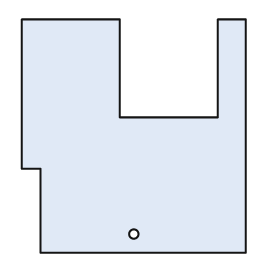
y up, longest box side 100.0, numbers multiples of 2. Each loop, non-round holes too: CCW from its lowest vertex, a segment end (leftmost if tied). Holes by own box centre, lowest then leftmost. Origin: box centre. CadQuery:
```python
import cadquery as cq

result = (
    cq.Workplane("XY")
    .moveTo(-40.0, -50.0)
    .lineTo(48.0, -50.0)
    .lineTo(48.0, 50.0)
    .lineTo(36.0, 50.0)
    .lineTo(36.0, 8.0)
    .lineTo(-6.0, 8.0)
    .lineTo(-6.0, 50.0)
    .lineTo(-48.0, 50.0)
    .lineTo(-48.0, -14.0)
    .lineTo(-40.0, -14.0)
    .close()
    .moveTo(0.0, -42.0)
    .circle(2.0)
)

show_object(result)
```